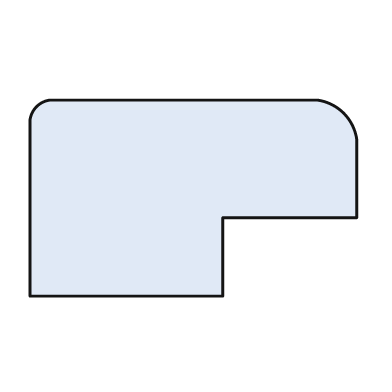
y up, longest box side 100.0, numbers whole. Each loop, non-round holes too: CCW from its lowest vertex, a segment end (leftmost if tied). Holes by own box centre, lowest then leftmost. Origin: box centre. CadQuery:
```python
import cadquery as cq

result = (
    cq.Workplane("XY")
    .moveTo(-50.0, -30.0)
    .lineTo(9.0, -30.0)
    .lineTo(9.0, -6.0)
    .lineTo(50.0, -6.0)
    .lineTo(50.0, 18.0)
    .threePointArc((46.0, 26.0), (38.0, 30.0))
    .lineTo(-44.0, 30.0)
    .threePointArc((-48.0, 28.0), (-50.0, 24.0))
    .close()
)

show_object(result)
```